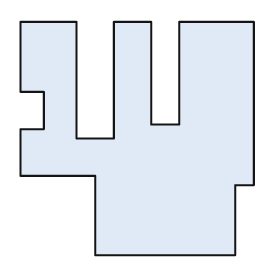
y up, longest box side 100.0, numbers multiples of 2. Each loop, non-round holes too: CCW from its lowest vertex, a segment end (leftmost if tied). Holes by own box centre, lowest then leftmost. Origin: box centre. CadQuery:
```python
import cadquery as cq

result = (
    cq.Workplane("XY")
    .moveTo(-18.0, -50.0)
    .lineTo(42.0, -50.0)
    .lineTo(42.0, -20.0)
    .lineTo(50.0, -20.0)
    .lineTo(50.0, 50.0)
    .lineTo(18.0, 50.0)
    .lineTo(18.0, 6.0)
    .lineTo(6.0, 6.0)
    .lineTo(6.0, 50.0)
    .lineTo(-10.0, 50.0)
    .lineTo(-10.0, 0.0)
    .lineTo(-26.0, 0.0)
    .lineTo(-26.0, 50.0)
    .lineTo(-50.0, 50.0)
    .lineTo(-50.0, 20.0)
    .lineTo(-40.0, 20.0)
    .lineTo(-40.0, 4.0)
    .lineTo(-50.0, 4.0)
    .lineTo(-50.0, -16.0)
    .lineTo(-18.0, -16.0)
    .close()
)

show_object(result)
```